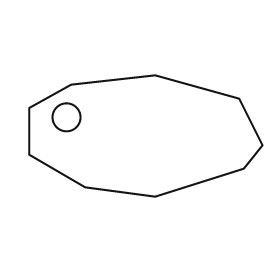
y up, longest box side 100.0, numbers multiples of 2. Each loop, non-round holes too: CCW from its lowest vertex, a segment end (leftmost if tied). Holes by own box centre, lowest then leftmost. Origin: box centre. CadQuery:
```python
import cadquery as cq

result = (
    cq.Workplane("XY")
    .moveTo(4.0, -26.0)
    .lineTo(42.0, -14.0)
    .lineTo(50.0, -4.0)
    .lineTo(40.0, 16.0)
    .lineTo(4.0, 26.0)
    .lineTo(-32.0, 22.0)
    .lineTo(-50.0, 12.0)
    .lineTo(-50.0, -8.0)
    .lineTo(-26.0, -22.0)
    .close()
    .moveTo(-34.0, 8.0)
    .circle(6.0)
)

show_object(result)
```